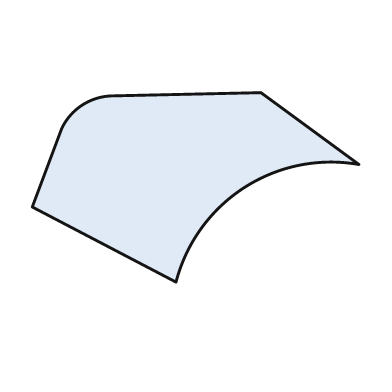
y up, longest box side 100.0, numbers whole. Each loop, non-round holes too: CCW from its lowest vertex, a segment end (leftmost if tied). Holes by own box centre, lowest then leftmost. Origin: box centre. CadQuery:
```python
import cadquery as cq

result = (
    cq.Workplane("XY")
    .moveTo(-6.0, -29.0)
    .threePointArc((15.0, 0.0), (50.0, 7.0))
    .lineTo(20.0, 29.0)
    .lineTo(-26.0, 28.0)
    .threePointArc((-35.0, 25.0), (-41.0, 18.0))
    .lineTo(-50.0, -6.0)
    .close()
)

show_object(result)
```